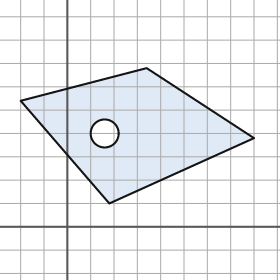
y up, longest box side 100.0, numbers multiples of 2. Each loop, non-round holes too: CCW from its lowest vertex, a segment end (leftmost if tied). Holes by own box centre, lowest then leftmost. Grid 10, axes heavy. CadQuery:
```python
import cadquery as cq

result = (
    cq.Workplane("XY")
    .moveTo(18.0, 10.0)
    .lineTo(80.0, 38.0)
    .lineTo(34.0, 68.0)
    .lineTo(-20.0, 54.0)
    .close()
    .moveTo(16.0, 40.0)
    .circle(6.0)
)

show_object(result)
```